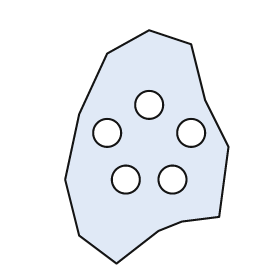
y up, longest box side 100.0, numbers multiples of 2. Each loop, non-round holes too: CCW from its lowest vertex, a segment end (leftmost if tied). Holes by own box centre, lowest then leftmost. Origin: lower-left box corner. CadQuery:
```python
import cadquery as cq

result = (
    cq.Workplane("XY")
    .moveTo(22.0, 0.0)
    .lineTo(40.0, 14.0)
    .lineTo(50.0, 18.0)
    .lineTo(66.0, 20.0)
    .lineTo(70.0, 50.0)
    .lineTo(60.0, 70.0)
    .lineTo(54.0, 94.0)
    .lineTo(36.0, 100.0)
    .lineTo(18.0, 90.0)
    .lineTo(6.0, 64.0)
    .lineTo(0.0, 36.0)
    .lineTo(6.0, 12.0)
    .close()
    .moveTo(26.0, 36.0)
    .circle(6.0)
    .moveTo(46.0, 36.0)
    .circle(6.0)
    .moveTo(18.0, 56.0)
    .circle(6.0)
    .moveTo(54.0, 56.0)
    .circle(6.0)
    .moveTo(36.0, 68.0)
    .circle(6.0)
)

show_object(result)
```